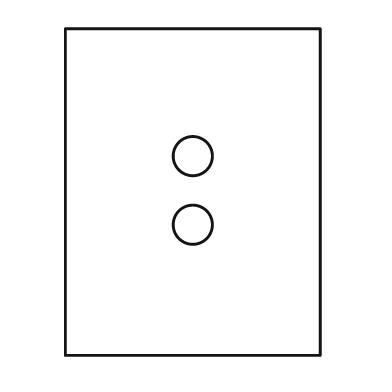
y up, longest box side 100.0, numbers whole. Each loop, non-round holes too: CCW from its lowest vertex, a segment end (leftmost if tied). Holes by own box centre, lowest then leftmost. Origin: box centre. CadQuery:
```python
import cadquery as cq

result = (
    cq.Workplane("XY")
    .moveTo(-39.0, -50.0)
    .lineTo(39.0, -50.0)
    .lineTo(39.0, 50.0)
    .lineTo(-39.0, 50.0)
    .close()
    .moveTo(0.0, -10.0)
    .circle(6.0)
    .moveTo(0.0, 11.0)
    .circle(6.0)
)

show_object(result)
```